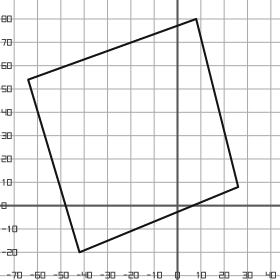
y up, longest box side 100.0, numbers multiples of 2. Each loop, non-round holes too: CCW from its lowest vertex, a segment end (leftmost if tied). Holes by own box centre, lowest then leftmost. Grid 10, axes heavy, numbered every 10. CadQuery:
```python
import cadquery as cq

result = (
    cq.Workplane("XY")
    .moveTo(-42.0, -20.0)
    .lineTo(26.0, 8.0)
    .lineTo(8.0, 80.0)
    .lineTo(-64.0, 54.0)
    .close()
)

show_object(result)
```